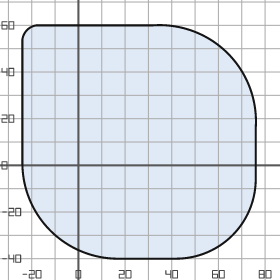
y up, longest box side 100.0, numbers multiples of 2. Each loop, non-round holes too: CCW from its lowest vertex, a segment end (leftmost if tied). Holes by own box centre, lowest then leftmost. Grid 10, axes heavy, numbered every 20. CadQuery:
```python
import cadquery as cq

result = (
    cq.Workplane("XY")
    .moveTo(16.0, -40.0)
    .lineTo(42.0, -40.0)
    .threePointArc((66.0, -30.0), (76.0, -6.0))
    .lineTo(76.0, 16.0)
    .threePointArc((64.0, 48.0), (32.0, 60.0))
    .lineTo(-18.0, 60.0)
    .threePointArc((-22.0, 58.0), (-24.0, 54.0))
    .lineTo(-24.0, 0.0)
    .threePointArc((-12.0, -28.0), (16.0, -40.0))
    .close()
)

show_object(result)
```